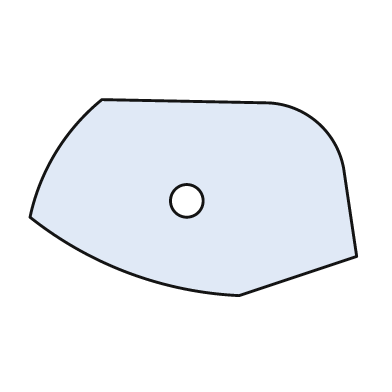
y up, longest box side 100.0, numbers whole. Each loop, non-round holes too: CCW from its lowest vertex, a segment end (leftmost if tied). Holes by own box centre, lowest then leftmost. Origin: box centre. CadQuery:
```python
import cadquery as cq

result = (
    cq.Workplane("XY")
    .moveTo(14.0, -30.0)
    .lineTo(50.0, -18.0)
    .lineTo(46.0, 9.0)
    .threePointArc((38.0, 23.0), (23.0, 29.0))
    .lineTo(-28.0, 30.0)
    .threePointArc((-42.0, 14.0), (-50.0, -6.0))
    .threePointArc((-20.0, -23.0), (14.0, -30.0))
    .close()
    .moveTo(-2.0, -1.0)
    .circle(5.0)
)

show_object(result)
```